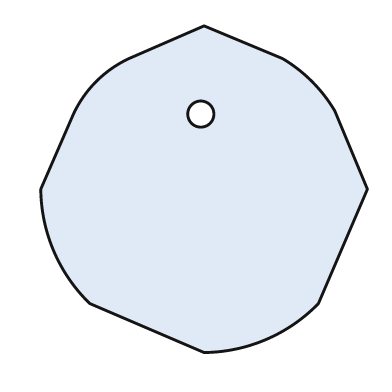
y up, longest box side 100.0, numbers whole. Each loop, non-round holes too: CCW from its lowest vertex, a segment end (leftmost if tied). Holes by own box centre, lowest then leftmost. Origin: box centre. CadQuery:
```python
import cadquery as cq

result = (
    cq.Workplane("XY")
    .moveTo(0.0, -50.0)
    .threePointArc((19.0, -46.0), (35.0, -35.0))
    .lineTo(50.0, 0.0)
    .lineTo(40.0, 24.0)
    .threePointArc((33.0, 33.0), (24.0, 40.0))
    .lineTo(0.0, 50.0)
    .lineTo(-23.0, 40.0)
    .threePointArc((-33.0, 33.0), (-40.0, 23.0))
    .lineTo(-50.0, 0.0)
    .threePointArc((-46.0, -19.0), (-35.0, -35.0))
    .close()
    .moveTo(-1.0, 23.0)
    .circle(4.0)
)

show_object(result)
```